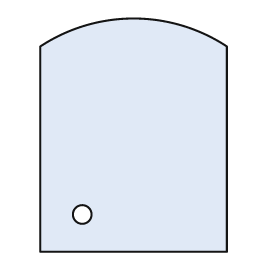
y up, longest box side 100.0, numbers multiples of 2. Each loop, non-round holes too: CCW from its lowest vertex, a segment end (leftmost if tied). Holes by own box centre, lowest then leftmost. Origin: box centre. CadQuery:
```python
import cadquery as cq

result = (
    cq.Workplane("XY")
    .moveTo(-40.0, -50.0)
    .lineTo(40.0, -50.0)
    .lineTo(40.0, 38.0)
    .threePointArc((0.0, 50.0), (-40.0, 38.0))
    .close()
    .moveTo(-22.0, -34.0)
    .circle(4.0)
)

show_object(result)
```